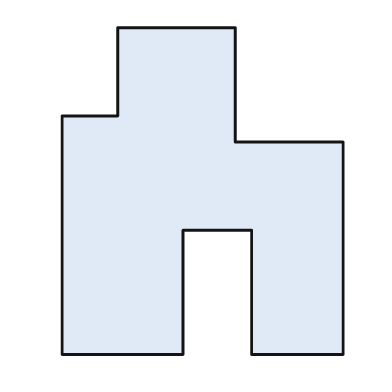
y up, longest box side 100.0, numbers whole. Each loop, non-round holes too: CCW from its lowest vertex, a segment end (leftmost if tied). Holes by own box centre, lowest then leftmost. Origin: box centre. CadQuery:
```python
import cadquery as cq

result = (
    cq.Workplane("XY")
    .moveTo(-43.0, -50.0)
    .lineTo(-6.0, -50.0)
    .lineTo(-6.0, -12.0)
    .lineTo(15.0, -12.0)
    .lineTo(15.0, -50.0)
    .lineTo(43.0, -50.0)
    .lineTo(43.0, 15.0)
    .lineTo(10.0, 15.0)
    .lineTo(10.0, 50.0)
    .lineTo(-26.0, 50.0)
    .lineTo(-26.0, 23.0)
    .lineTo(-43.0, 23.0)
    .close()
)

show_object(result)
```